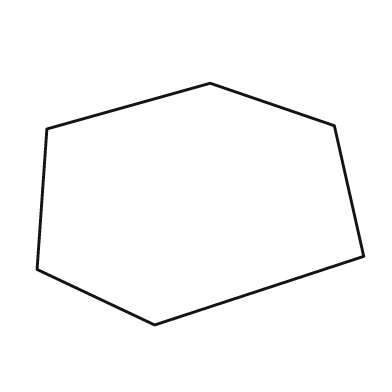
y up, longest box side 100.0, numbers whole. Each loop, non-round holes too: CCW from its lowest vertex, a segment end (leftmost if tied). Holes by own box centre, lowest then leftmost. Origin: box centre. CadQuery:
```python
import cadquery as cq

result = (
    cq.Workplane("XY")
    .moveTo(-14.0, -37.0)
    .lineTo(50.0, -16.0)
    .lineTo(41.0, 24.0)
    .lineTo(3.0, 37.0)
    .lineTo(-47.0, 23.0)
    .lineTo(-50.0, -20.0)
    .close()
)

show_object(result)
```